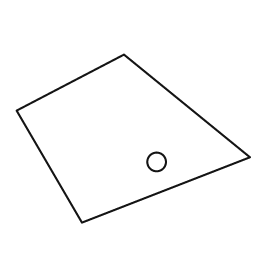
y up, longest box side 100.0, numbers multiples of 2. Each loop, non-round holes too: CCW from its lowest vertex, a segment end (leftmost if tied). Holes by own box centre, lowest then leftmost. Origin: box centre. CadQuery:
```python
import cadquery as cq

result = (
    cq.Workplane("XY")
    .moveTo(-22.0, -36.0)
    .lineTo(50.0, -8.0)
    .lineTo(-4.0, 36.0)
    .lineTo(-50.0, 12.0)
    .close()
    .moveTo(10.0, -10.0)
    .circle(4.0)
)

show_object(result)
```